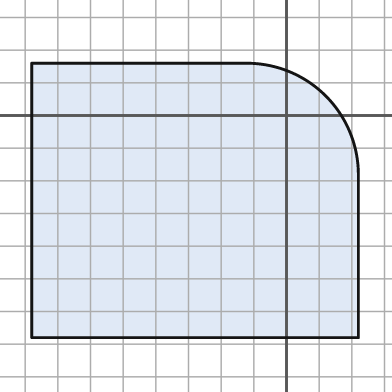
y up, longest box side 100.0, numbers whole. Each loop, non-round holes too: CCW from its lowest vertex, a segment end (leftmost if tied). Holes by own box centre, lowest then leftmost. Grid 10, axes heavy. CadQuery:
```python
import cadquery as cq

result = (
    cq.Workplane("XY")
    .moveTo(-78.0, -68.0)
    .lineTo(22.0, -68.0)
    .lineTo(22.0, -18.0)
    .threePointArc((12.0, 6.0), (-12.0, 16.0))
    .lineTo(-78.0, 16.0)
    .close()
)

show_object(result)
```